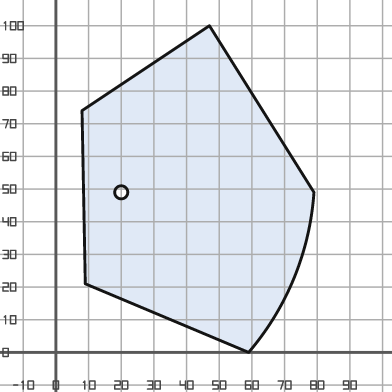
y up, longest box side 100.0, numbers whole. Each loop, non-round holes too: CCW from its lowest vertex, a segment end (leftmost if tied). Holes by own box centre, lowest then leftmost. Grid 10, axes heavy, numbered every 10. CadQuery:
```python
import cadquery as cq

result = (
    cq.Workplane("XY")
    .moveTo(59.0, 0.0)
    .threePointArc((73.0, 23.0), (79.0, 49.0))
    .lineTo(47.0, 100.0)
    .lineTo(8.0, 74.0)
    .lineTo(9.0, 21.0)
    .close()
    .moveTo(20.0, 49.0)
    .circle(2.0)
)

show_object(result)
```